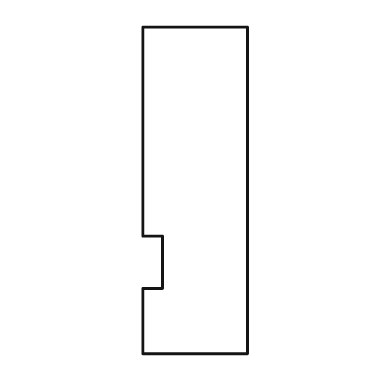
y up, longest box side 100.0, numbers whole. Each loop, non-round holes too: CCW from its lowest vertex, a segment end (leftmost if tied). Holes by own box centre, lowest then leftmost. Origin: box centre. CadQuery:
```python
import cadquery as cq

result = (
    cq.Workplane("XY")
    .moveTo(-16.0, -50.0)
    .lineTo(16.0, -50.0)
    .lineTo(16.0, 50.0)
    .lineTo(-16.0, 50.0)
    .lineTo(-16.0, -14.0)
    .lineTo(-10.0, -14.0)
    .lineTo(-10.0, -30.0)
    .lineTo(-16.0, -30.0)
    .close()
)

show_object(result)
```